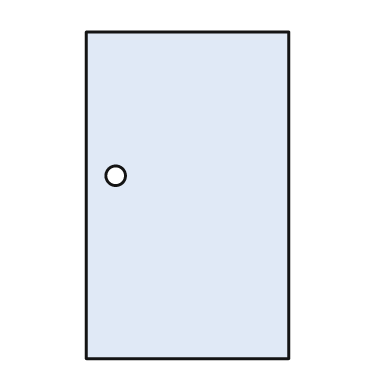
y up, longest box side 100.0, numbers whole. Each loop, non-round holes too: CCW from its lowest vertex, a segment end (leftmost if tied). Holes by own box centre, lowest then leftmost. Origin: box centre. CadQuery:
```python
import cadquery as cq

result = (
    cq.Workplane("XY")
    .moveTo(-31.0, -50.0)
    .lineTo(31.0, -50.0)
    .lineTo(31.0, 50.0)
    .lineTo(-31.0, 50.0)
    .close()
    .moveTo(-22.0, 6.0)
    .circle(3.0)
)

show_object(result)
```